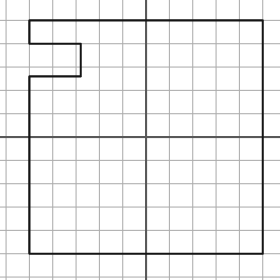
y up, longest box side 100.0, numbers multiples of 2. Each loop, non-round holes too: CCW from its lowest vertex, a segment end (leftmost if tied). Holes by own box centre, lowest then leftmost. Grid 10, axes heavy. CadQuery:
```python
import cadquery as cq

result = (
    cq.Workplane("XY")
    .moveTo(-50.0, -50.0)
    .lineTo(50.0, -50.0)
    .lineTo(50.0, 50.0)
    .lineTo(-50.0, 50.0)
    .lineTo(-50.0, 40.0)
    .lineTo(-28.0, 40.0)
    .lineTo(-28.0, 26.0)
    .lineTo(-50.0, 26.0)
    .close()
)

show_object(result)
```